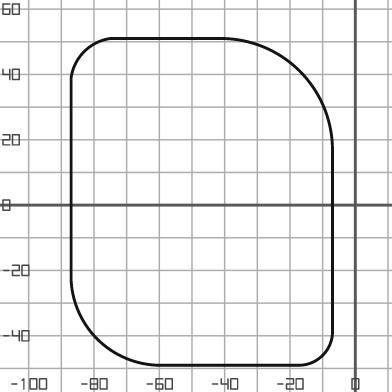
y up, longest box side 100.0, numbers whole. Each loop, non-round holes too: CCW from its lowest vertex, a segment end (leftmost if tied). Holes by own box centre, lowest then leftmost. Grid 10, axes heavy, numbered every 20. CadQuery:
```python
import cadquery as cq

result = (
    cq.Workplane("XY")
    .moveTo(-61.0, -49.0)
    .lineTo(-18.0, -49.0)
    .threePointArc((-10.0, -46.0), (-7.0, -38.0))
    .lineTo(-7.0, 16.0)
    .threePointArc((-17.0, 41.0), (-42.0, 51.0))
    .lineTo(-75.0, 51.0)
    .threePointArc((-83.0, 47.0), (-87.0, 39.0))
    .lineTo(-87.0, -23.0)
    .threePointArc((-79.0, -41.0), (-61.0, -49.0))
    .close()
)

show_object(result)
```